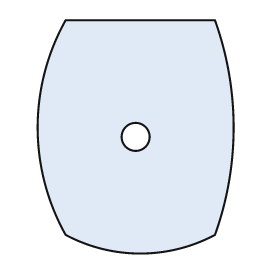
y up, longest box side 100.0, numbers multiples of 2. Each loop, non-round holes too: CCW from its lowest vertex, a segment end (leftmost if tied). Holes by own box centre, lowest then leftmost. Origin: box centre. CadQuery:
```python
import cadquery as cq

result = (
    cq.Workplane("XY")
    .moveTo(-30.0, -42.0)
    .threePointArc((2.0, -50.0), (34.0, -42.0))
    .threePointArc((42.0, 4.0), (34.0, 50.0))
    .lineTo(-30.0, 50.0)
    .threePointArc((-42.0, 4.0), (-30.0, -42.0))
    .close()
    .moveTo(0.0, 0.0)
    .circle(6.0)
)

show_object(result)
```